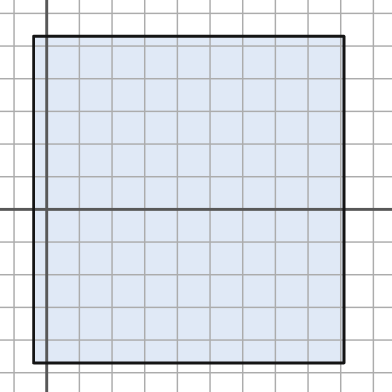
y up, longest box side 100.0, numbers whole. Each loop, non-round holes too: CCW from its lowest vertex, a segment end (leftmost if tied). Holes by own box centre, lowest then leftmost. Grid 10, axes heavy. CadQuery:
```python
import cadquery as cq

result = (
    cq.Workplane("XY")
    .moveTo(-4.0, -47.0)
    .lineTo(91.0, -47.0)
    .lineTo(91.0, 53.0)
    .lineTo(-4.0, 53.0)
    .close()
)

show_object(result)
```